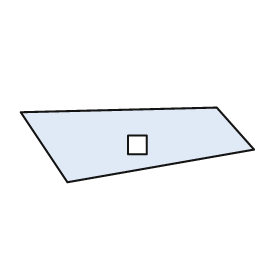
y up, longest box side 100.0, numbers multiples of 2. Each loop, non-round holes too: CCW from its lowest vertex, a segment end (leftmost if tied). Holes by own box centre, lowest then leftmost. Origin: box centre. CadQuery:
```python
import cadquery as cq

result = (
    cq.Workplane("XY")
    .moveTo(-30.0, -16.0)
    .lineTo(50.0, -2.0)
    .lineTo(34.0, 16.0)
    .lineTo(-50.0, 14.0)
    .close()
    .moveTo(-4.0, -4.0)
    .lineTo(4.0, -4.0)
    .lineTo(4.0, 4.0)
    .lineTo(-4.0, 4.0)
    .close()
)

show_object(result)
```